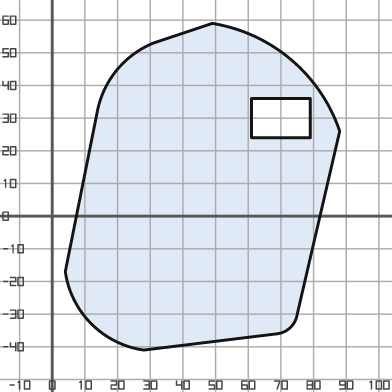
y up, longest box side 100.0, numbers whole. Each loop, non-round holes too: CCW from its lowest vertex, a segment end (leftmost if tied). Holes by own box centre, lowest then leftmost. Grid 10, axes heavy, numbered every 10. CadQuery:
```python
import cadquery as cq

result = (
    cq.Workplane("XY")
    .moveTo(28.0, -41.0)
    .lineTo(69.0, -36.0)
    .threePointArc((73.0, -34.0), (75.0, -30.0))
    .lineTo(88.0, 26.0)
    .threePointArc((73.0, 48.0), (49.0, 59.0))
    .lineTo(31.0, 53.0)
    .threePointArc((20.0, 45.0), (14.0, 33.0))
    .lineTo(4.0, -17.0)
    .threePointArc((12.0, -33.0), (28.0, -41.0))
    .close()
    .moveTo(61.0, 24.0)
    .lineTo(79.0, 24.0)
    .lineTo(79.0, 36.0)
    .lineTo(61.0, 36.0)
    .close()
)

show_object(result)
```